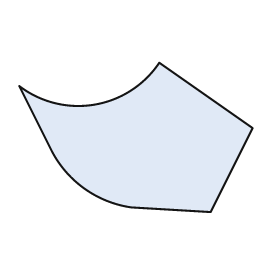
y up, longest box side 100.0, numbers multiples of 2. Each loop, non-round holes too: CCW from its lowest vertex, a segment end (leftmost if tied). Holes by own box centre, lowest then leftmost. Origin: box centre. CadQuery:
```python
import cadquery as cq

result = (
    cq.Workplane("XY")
    .moveTo(32.0, -32.0)
    .lineTo(50.0, 4.0)
    .lineTo(10.0, 32.0)
    .threePointArc((-18.0, 14.0), (-50.0, 22.0))
    .lineTo(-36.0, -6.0)
    .threePointArc((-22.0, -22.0), (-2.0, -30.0))
    .close()
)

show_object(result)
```